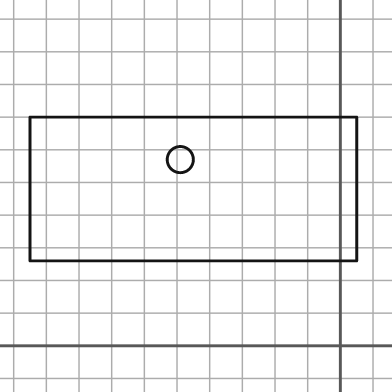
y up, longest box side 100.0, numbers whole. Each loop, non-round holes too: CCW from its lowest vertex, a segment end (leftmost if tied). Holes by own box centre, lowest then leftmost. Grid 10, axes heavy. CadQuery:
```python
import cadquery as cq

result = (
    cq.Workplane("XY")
    .moveTo(-95.0, 26.0)
    .lineTo(5.0, 26.0)
    .lineTo(5.0, 70.0)
    .lineTo(-95.0, 70.0)
    .close()
    .moveTo(-49.0, 57.0)
    .circle(4.0)
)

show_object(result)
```